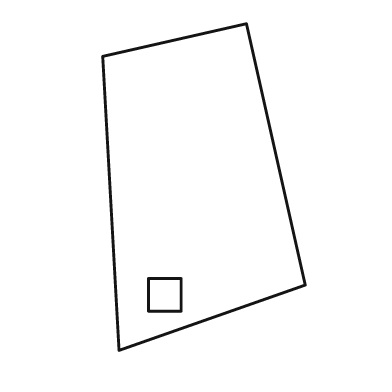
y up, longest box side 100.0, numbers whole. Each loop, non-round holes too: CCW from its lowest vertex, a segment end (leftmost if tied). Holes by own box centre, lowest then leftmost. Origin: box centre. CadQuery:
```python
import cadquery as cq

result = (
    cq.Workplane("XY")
    .moveTo(-26.0, -50.0)
    .lineTo(31.0, -30.0)
    .lineTo(13.0, 50.0)
    .lineTo(-31.0, 40.0)
    .close()
    .moveTo(-17.0, -38.0)
    .lineTo(-7.0, -38.0)
    .lineTo(-7.0, -28.0)
    .lineTo(-17.0, -28.0)
    .close()
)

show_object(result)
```